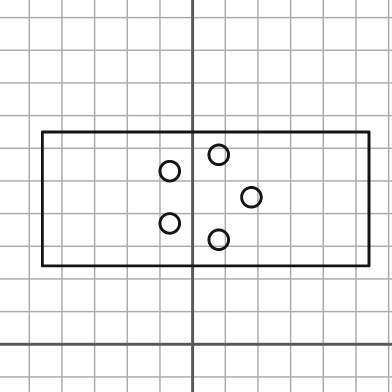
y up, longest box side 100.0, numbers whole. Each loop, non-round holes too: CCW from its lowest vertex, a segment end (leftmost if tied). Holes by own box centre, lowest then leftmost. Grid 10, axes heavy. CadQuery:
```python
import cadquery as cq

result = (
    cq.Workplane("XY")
    .moveTo(-46.0, 24.0)
    .lineTo(54.0, 24.0)
    .lineTo(54.0, 65.0)
    .lineTo(-46.0, 65.0)
    .close()
    .moveTo(8.0, 32.0)
    .circle(3.0)
    .moveTo(-7.0, 37.0)
    .circle(3.0)
    .moveTo(18.0, 45.0)
    .circle(3.0)
    .moveTo(-7.0, 53.0)
    .circle(3.0)
    .moveTo(8.0, 58.0)
    .circle(3.0)
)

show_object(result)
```